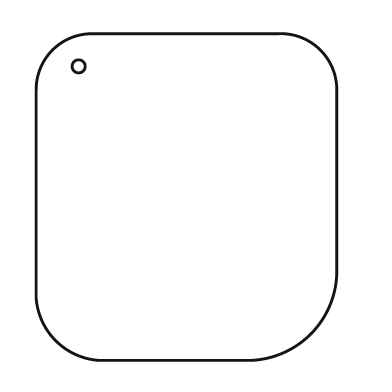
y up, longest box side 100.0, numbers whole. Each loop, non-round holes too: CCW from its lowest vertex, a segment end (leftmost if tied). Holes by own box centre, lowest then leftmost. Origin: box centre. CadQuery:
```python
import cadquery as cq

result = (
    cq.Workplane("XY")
    .moveTo(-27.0, -50.0)
    .lineTo(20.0, -50.0)
    .threePointArc((38.0, -42.0), (46.0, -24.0))
    .lineTo(46.0, 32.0)
    .threePointArc((41.0, 45.0), (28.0, 50.0))
    .lineTo(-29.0, 50.0)
    .threePointArc((-41.0, 45.0), (-46.0, 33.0))
    .lineTo(-46.0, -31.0)
    .threePointArc((-40.0, -44.0), (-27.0, -50.0))
    .close()
    .moveTo(-33.0, 40.0)
    .circle(2.0)
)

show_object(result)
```